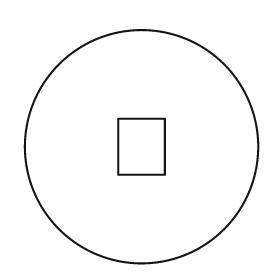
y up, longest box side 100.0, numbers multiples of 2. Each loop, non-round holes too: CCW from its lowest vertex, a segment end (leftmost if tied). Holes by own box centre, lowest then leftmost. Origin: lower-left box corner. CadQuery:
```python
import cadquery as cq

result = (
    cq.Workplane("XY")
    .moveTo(50.0, 50.0)
    .circle(50.0)
    .moveTo(40.0, 38.0)
    .lineTo(60.0, 38.0)
    .lineTo(60.0, 62.0)
    .lineTo(40.0, 62.0)
    .close()
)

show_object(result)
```